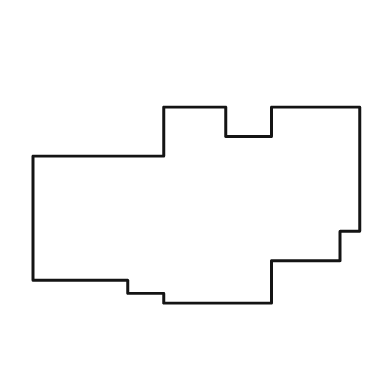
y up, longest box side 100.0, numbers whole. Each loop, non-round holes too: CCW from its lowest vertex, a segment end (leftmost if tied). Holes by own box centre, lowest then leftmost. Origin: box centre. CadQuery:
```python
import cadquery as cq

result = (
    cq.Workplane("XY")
    .moveTo(-10.0, -30.0)
    .lineTo(23.0, -30.0)
    .lineTo(23.0, -17.0)
    .lineTo(44.0, -17.0)
    .lineTo(44.0, -8.0)
    .lineTo(50.0, -8.0)
    .lineTo(50.0, 30.0)
    .lineTo(23.0, 30.0)
    .lineTo(23.0, 21.0)
    .lineTo(9.0, 21.0)
    .lineTo(9.0, 30.0)
    .lineTo(-10.0, 30.0)
    .lineTo(-10.0, 15.0)
    .lineTo(-50.0, 15.0)
    .lineTo(-50.0, -23.0)
    .lineTo(-21.0, -23.0)
    .lineTo(-21.0, -27.0)
    .lineTo(-10.0, -27.0)
    .close()
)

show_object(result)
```